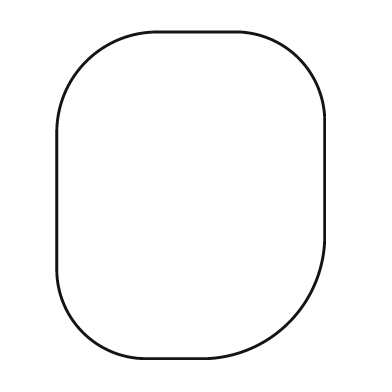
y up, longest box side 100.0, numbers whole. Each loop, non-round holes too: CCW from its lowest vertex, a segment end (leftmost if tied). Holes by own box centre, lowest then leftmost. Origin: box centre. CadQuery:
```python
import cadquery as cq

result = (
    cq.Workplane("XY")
    .moveTo(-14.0, -50.0)
    .lineTo(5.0, -50.0)
    .threePointArc((30.0, -39.0), (41.0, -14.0))
    .lineTo(41.0, 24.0)
    .threePointArc((33.0, 42.0), (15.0, 50.0))
    .lineTo(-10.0, 50.0)
    .threePointArc((-32.0, 41.0), (-41.0, 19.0))
    .lineTo(-41.0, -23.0)
    .threePointArc((-33.0, -42.0), (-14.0, -50.0))
    .close()
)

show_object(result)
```